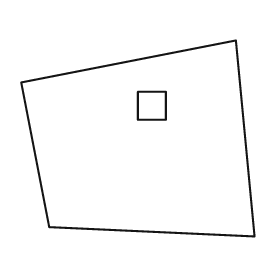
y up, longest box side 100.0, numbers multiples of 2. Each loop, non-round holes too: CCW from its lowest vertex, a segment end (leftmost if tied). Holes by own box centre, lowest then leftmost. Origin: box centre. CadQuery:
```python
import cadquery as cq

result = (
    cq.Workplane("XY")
    .moveTo(50.0, -42.0)
    .lineTo(42.0, 42.0)
    .lineTo(-50.0, 24.0)
    .lineTo(-38.0, -38.0)
    .close()
    .moveTo(0.0, 8.0)
    .lineTo(12.0, 8.0)
    .lineTo(12.0, 20.0)
    .lineTo(0.0, 20.0)
    .close()
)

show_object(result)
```